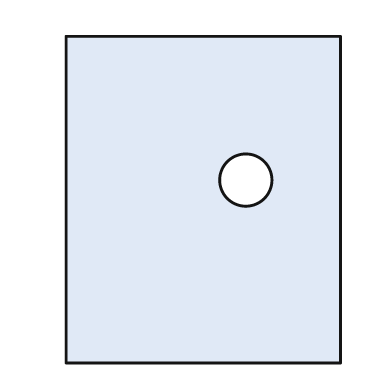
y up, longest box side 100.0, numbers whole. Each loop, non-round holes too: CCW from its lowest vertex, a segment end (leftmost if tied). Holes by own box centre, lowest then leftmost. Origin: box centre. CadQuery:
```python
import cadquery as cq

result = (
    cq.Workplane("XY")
    .moveTo(-42.0, -50.0)
    .lineTo(42.0, -50.0)
    .lineTo(42.0, 50.0)
    .lineTo(-42.0, 50.0)
    .close()
    .moveTo(13.0, 6.0)
    .circle(8.0)
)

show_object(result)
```